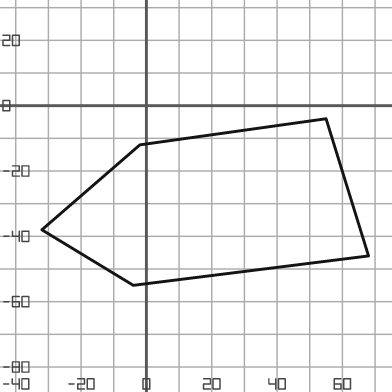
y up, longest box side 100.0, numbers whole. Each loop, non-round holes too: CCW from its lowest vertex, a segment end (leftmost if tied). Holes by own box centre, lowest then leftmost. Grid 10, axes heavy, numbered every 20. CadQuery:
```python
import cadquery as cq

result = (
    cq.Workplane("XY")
    .moveTo(-4.0, -55.0)
    .lineTo(68.0, -46.0)
    .lineTo(55.0, -4.0)
    .lineTo(-2.0, -12.0)
    .lineTo(-32.0, -38.0)
    .close()
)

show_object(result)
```